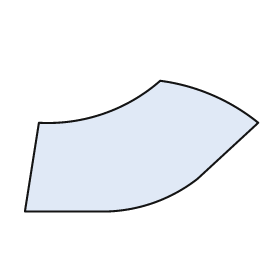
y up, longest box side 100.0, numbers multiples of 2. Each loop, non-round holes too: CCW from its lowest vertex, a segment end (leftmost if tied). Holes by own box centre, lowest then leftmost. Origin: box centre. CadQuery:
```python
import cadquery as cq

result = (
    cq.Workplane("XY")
    .moveTo(-50.0, -28.0)
    .lineTo(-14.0, -28.0)
    .threePointArc((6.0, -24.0), (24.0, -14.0))
    .lineTo(50.0, 10.0)
    .threePointArc((30.0, 22.0), (8.0, 28.0))
    .threePointArc((-16.0, 14.0), (-44.0, 10.0))
    .close()
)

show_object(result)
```